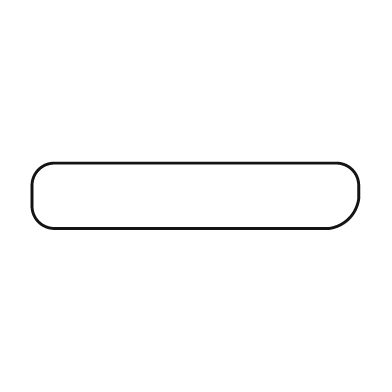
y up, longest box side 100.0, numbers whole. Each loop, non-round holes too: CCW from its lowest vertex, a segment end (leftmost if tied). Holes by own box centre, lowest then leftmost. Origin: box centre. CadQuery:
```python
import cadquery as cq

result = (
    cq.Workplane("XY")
    .moveTo(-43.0, -10.0)
    .lineTo(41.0, -10.0)
    .threePointArc((47.0, -7.0), (50.0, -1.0))
    .lineTo(50.0, 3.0)
    .threePointArc((48.0, 8.0), (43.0, 10.0))
    .lineTo(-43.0, 10.0)
    .threePointArc((-48.0, 8.0), (-50.0, 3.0))
    .lineTo(-50.0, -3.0)
    .threePointArc((-48.0, -8.0), (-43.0, -10.0))
    .close()
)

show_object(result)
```